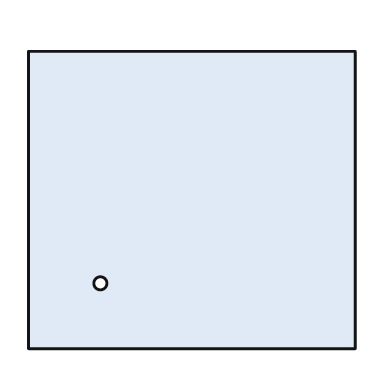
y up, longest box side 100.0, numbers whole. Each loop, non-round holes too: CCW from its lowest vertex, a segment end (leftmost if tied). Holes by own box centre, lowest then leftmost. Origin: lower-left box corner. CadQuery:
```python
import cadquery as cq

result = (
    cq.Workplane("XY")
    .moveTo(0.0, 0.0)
    .lineTo(100.0, 0.0)
    .lineTo(100.0, 91.0)
    .lineTo(0.0, 91.0)
    .close()
    .moveTo(22.0, 20.0)
    .circle(2.0)
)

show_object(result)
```